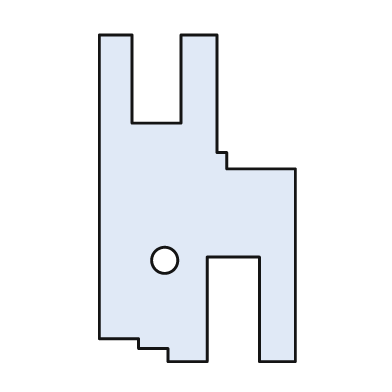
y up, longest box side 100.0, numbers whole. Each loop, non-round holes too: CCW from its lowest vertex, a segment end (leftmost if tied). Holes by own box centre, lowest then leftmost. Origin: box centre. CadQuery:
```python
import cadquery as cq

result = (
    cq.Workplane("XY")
    .moveTo(-9.0, -50.0)
    .lineTo(3.0, -50.0)
    .lineTo(3.0, -18.0)
    .lineTo(19.0, -18.0)
    .lineTo(19.0, -50.0)
    .lineTo(30.0, -50.0)
    .lineTo(30.0, 9.0)
    .lineTo(9.0, 9.0)
    .lineTo(9.0, 14.0)
    .lineTo(6.0, 14.0)
    .lineTo(6.0, 50.0)
    .lineTo(-5.0, 50.0)
    .lineTo(-5.0, 23.0)
    .lineTo(-20.0, 23.0)
    .lineTo(-20.0, 50.0)
    .lineTo(-30.0, 50.0)
    .lineTo(-30.0, -43.0)
    .lineTo(-18.0, -43.0)
    .lineTo(-18.0, -46.0)
    .lineTo(-9.0, -46.0)
    .close()
    .moveTo(-10.0, -19.0)
    .circle(4.0)
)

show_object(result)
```